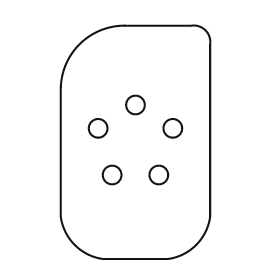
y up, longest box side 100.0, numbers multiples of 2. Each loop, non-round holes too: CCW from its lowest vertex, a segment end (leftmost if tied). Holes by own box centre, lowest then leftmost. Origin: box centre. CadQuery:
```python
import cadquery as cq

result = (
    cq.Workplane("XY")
    .moveTo(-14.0, -50.0)
    .lineTo(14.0, -50.0)
    .threePointArc((26.0, -44.0), (32.0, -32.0))
    .lineTo(32.0, 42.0)
    .threePointArc((30.0, 48.0), (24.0, 50.0))
    .lineTo(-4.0, 50.0)
    .threePointArc((-24.0, 42.0), (-32.0, 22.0))
    .lineTo(-32.0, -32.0)
    .threePointArc((-26.0, -44.0), (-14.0, -50.0))
    .close()
    .moveTo(-10.0, -14.0)
    .circle(4.0)
    .moveTo(10.0, -14.0)
    .circle(4.0)
    .moveTo(-16.0, 6.0)
    .circle(4.0)
    .moveTo(16.0, 6.0)
    .circle(4.0)
    .moveTo(0.0, 16.0)
    .circle(4.0)
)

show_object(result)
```